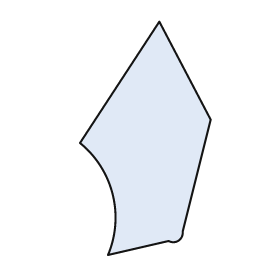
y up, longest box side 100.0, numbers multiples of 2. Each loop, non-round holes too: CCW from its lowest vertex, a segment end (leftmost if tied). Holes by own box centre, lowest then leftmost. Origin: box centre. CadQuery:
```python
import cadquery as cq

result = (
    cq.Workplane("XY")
    .moveTo(-16.0, -50.0)
    .lineTo(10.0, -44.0)
    .threePointArc((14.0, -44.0), (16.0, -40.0))
    .lineTo(28.0, 8.0)
    .lineTo(6.0, 50.0)
    .lineTo(-28.0, -2.0)
    .threePointArc((-14.0, -24.0), (-16.0, -50.0))
    .close()
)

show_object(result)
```